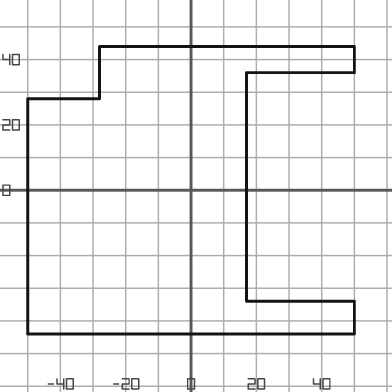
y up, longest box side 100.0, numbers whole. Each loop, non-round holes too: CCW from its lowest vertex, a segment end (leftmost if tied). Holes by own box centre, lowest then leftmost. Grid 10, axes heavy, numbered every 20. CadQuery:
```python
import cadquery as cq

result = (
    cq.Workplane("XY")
    .moveTo(-50.0, -44.0)
    .lineTo(50.0, -44.0)
    .lineTo(50.0, -34.0)
    .lineTo(17.0, -34.0)
    .lineTo(17.0, 36.0)
    .lineTo(50.0, 36.0)
    .lineTo(50.0, 44.0)
    .lineTo(-28.0, 44.0)
    .lineTo(-28.0, 28.0)
    .lineTo(-50.0, 28.0)
    .close()
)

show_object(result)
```